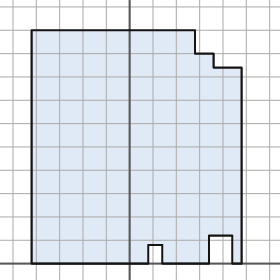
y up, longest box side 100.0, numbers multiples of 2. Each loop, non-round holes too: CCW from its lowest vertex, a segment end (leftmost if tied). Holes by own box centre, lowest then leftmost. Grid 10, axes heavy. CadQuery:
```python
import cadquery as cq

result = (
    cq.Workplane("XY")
    .moveTo(-42.0, 0.0)
    .lineTo(8.0, 0.0)
    .lineTo(8.0, 8.0)
    .lineTo(14.0, 8.0)
    .lineTo(14.0, 0.0)
    .lineTo(34.0, 0.0)
    .lineTo(34.0, 12.0)
    .lineTo(44.0, 12.0)
    .lineTo(44.0, 0.0)
    .lineTo(48.0, 0.0)
    .lineTo(48.0, 84.0)
    .lineTo(36.0, 84.0)
    .lineTo(36.0, 90.0)
    .lineTo(28.0, 90.0)
    .lineTo(28.0, 100.0)
    .lineTo(-42.0, 100.0)
    .close()
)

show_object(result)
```